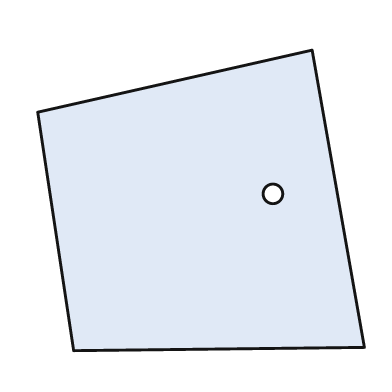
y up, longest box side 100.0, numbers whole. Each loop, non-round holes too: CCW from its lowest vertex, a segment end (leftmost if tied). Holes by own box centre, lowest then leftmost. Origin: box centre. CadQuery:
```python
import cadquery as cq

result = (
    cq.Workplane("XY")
    .moveTo(-39.0, -46.0)
    .lineTo(50.0, -45.0)
    .lineTo(34.0, 46.0)
    .lineTo(-50.0, 27.0)
    .close()
    .moveTo(22.0, 2.0)
    .circle(3.0)
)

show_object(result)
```